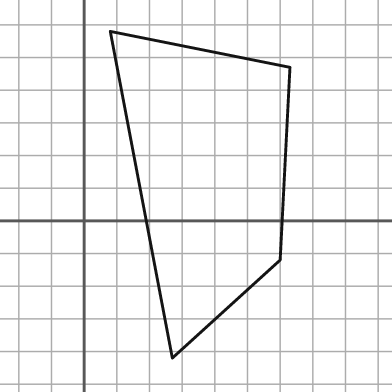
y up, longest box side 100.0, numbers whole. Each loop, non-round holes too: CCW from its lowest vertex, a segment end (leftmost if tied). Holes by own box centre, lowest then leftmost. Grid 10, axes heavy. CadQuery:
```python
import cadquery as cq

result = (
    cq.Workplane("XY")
    .moveTo(27.0, -42.0)
    .lineTo(60.0, -12.0)
    .lineTo(63.0, 47.0)
    .lineTo(8.0, 58.0)
    .close()
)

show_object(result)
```